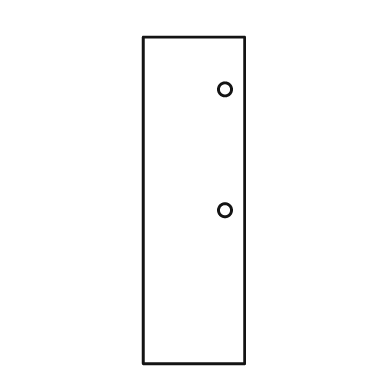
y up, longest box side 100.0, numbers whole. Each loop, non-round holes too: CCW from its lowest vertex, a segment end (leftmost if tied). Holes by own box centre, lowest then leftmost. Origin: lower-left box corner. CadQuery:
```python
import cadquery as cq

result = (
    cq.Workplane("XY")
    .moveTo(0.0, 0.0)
    .lineTo(31.0, 0.0)
    .lineTo(31.0, 100.0)
    .lineTo(0.0, 100.0)
    .close()
    .moveTo(25.0, 47.0)
    .circle(2.0)
    .moveTo(25.0, 84.0)
    .circle(2.0)
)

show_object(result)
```